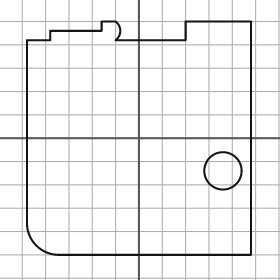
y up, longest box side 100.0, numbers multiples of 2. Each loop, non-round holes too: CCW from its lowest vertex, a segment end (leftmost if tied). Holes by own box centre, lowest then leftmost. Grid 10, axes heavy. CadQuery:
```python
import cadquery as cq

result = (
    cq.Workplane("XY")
    .moveTo(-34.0, -50.0)
    .lineTo(48.0, -50.0)
    .lineTo(48.0, 50.0)
    .lineTo(20.0, 50.0)
    .lineTo(20.0, 42.0)
    .lineTo(-10.0, 42.0)
    .threePointArc((-8.0, 46.0), (-10.0, 50.0))
    .lineTo(-16.0, 50.0)
    .lineTo(-16.0, 46.0)
    .lineTo(-38.0, 46.0)
    .lineTo(-38.0, 42.0)
    .lineTo(-48.0, 42.0)
    .lineTo(-48.0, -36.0)
    .threePointArc((-44.0, -46.0), (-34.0, -50.0))
    .close()
    .moveTo(36.0, -14.0)
    .circle(8.0)
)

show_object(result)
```